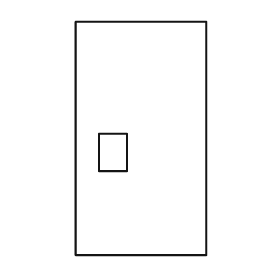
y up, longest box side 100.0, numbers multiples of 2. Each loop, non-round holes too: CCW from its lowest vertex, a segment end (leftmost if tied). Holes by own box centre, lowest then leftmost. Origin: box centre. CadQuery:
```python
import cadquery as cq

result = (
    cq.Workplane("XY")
    .moveTo(-28.0, -50.0)
    .lineTo(28.0, -50.0)
    .lineTo(28.0, 50.0)
    .lineTo(-28.0, 50.0)
    .close()
    .moveTo(-18.0, -14.0)
    .lineTo(-6.0, -14.0)
    .lineTo(-6.0, 2.0)
    .lineTo(-18.0, 2.0)
    .close()
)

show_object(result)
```